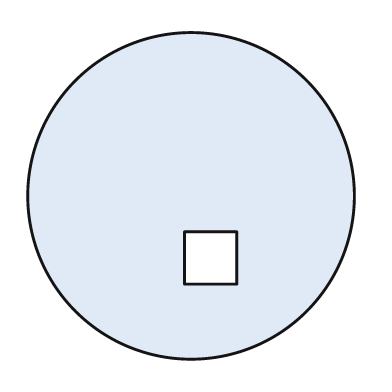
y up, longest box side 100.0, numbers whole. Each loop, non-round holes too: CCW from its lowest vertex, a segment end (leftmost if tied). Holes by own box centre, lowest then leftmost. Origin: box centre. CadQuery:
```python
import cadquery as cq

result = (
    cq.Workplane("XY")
    .moveTo(0.0, 0.0)
    .circle(50.0)
    .moveTo(-2.0, -27.0)
    .lineTo(14.0, -27.0)
    .lineTo(14.0, -11.0)
    .lineTo(-2.0, -11.0)
    .close()
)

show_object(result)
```